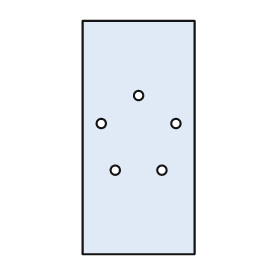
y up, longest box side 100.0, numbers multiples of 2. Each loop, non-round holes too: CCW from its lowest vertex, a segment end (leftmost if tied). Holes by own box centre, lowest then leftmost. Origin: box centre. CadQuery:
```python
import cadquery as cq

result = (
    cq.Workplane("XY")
    .moveTo(-24.0, -50.0)
    .lineTo(24.0, -50.0)
    .lineTo(24.0, 50.0)
    .lineTo(-24.0, 50.0)
    .close()
    .moveTo(-10.0, -14.0)
    .circle(2.0)
    .moveTo(10.0, -14.0)
    .circle(2.0)
    .moveTo(-16.0, 6.0)
    .circle(2.0)
    .moveTo(16.0, 6.0)
    .circle(2.0)
    .moveTo(0.0, 18.0)
    .circle(2.0)
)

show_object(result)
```